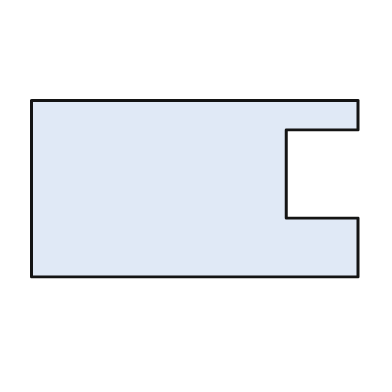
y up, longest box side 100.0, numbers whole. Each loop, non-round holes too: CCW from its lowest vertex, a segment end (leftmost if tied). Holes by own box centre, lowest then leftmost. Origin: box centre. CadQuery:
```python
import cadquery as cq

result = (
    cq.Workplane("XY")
    .moveTo(-50.0, -27.0)
    .lineTo(50.0, -27.0)
    .lineTo(50.0, -9.0)
    .lineTo(28.0, -9.0)
    .lineTo(28.0, 18.0)
    .lineTo(50.0, 18.0)
    .lineTo(50.0, 27.0)
    .lineTo(-50.0, 27.0)
    .close()
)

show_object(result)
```